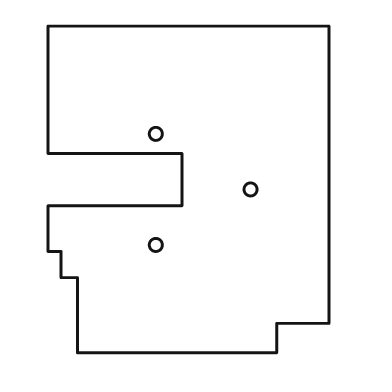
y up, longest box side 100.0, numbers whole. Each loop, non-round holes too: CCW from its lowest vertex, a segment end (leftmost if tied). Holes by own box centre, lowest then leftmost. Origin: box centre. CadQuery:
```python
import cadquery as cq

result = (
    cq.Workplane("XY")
    .moveTo(-34.0, -50.0)
    .lineTo(27.0, -50.0)
    .lineTo(27.0, -41.0)
    .lineTo(43.0, -41.0)
    .lineTo(43.0, 50.0)
    .lineTo(-43.0, 50.0)
    .lineTo(-43.0, 11.0)
    .lineTo(-2.0, 11.0)
    .lineTo(-2.0, -5.0)
    .lineTo(-43.0, -5.0)
    .lineTo(-43.0, -19.0)
    .lineTo(-39.0, -19.0)
    .lineTo(-39.0, -27.0)
    .lineTo(-34.0, -27.0)
    .close()
    .moveTo(-10.0, -17.0)
    .circle(2.0)
    .moveTo(19.0, 0.0)
    .circle(2.0)
    .moveTo(-10.0, 17.0)
    .circle(2.0)
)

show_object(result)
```